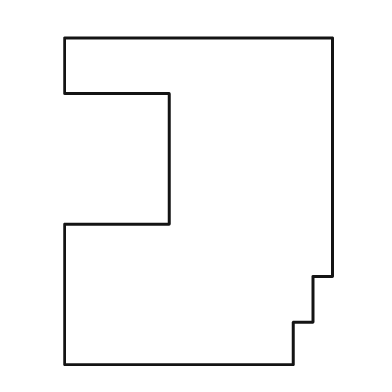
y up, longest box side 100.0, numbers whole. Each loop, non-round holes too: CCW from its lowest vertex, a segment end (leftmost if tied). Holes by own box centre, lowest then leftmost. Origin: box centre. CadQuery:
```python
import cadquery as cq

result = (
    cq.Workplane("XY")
    .moveTo(-41.0, -50.0)
    .lineTo(29.0, -50.0)
    .lineTo(29.0, -37.0)
    .lineTo(35.0, -37.0)
    .lineTo(35.0, -23.0)
    .lineTo(41.0, -23.0)
    .lineTo(41.0, 50.0)
    .lineTo(-41.0, 50.0)
    .lineTo(-41.0, 33.0)
    .lineTo(-9.0, 33.0)
    .lineTo(-9.0, -7.0)
    .lineTo(-41.0, -7.0)
    .close()
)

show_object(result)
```